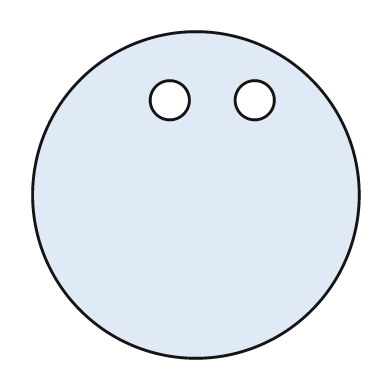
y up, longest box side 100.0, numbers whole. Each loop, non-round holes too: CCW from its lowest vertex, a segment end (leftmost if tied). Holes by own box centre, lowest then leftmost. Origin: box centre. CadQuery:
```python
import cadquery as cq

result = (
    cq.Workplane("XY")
    .moveTo(0.0, 0.0)
    .circle(50.0)
    .moveTo(-8.0, 29.0)
    .circle(6.0)
    .moveTo(18.0, 29.0)
    .circle(6.0)
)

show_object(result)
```